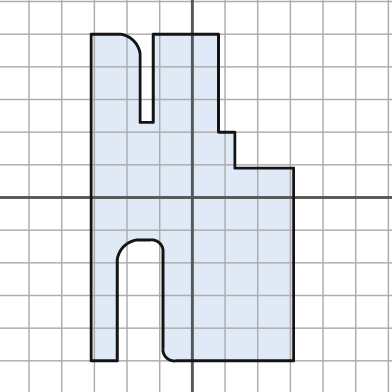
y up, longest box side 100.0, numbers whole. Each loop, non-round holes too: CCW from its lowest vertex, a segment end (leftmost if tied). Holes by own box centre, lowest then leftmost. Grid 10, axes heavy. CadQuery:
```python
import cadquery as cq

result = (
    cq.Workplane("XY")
    .moveTo(-31.0, -50.0)
    .lineTo(-23.0, -50.0)
    .lineTo(-23.0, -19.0)
    .threePointArc((-21.0, -15.0), (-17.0, -13.0))
    .lineTo(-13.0, -13.0)
    .threePointArc((-10.0, -14.0), (-9.0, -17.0))
    .lineTo(-9.0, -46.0)
    .threePointArc((-8.0, -49.0), (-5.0, -50.0))
    .lineTo(31.0, -50.0)
    .lineTo(31.0, 9.0)
    .lineTo(13.0, 9.0)
    .lineTo(13.0, 20.0)
    .lineTo(8.0, 20.0)
    .lineTo(8.0, 50.0)
    .lineTo(-12.0, 50.0)
    .lineTo(-12.0, 23.0)
    .lineTo(-16.0, 23.0)
    .lineTo(-16.0, 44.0)
    .threePointArc((-18.0, 48.0), (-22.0, 50.0))
    .lineTo(-31.0, 50.0)
    .close()
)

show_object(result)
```